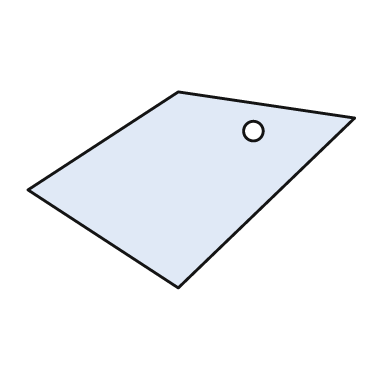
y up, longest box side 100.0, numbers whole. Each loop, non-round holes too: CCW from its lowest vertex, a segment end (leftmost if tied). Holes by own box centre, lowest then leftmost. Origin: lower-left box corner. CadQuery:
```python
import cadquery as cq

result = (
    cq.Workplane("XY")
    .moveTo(46.0, 0.0)
    .lineTo(100.0, 52.0)
    .lineTo(46.0, 60.0)
    .lineTo(0.0, 30.0)
    .close()
    .moveTo(69.0, 48.0)
    .circle(3.0)
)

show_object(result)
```